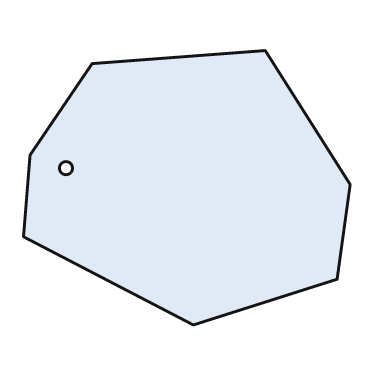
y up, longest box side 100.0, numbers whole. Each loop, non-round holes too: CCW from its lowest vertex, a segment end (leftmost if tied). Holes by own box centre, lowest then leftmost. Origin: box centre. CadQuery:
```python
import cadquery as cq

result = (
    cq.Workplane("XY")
    .moveTo(2.0, -42.0)
    .lineTo(46.0, -28.0)
    .lineTo(50.0, 1.0)
    .lineTo(24.0, 42.0)
    .lineTo(-29.0, 38.0)
    .lineTo(-48.0, 10.0)
    .lineTo(-50.0, -15.0)
    .close()
    .moveTo(-37.0, 6.0)
    .circle(2.0)
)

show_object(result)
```